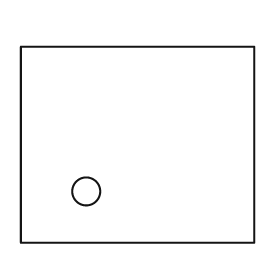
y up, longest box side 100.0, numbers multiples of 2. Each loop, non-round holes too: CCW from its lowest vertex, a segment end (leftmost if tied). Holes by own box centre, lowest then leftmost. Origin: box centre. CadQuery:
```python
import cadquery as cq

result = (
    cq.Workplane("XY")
    .moveTo(-50.0, -42.0)
    .lineTo(50.0, -42.0)
    .lineTo(50.0, 42.0)
    .lineTo(-50.0, 42.0)
    .close()
    .moveTo(-22.0, -20.0)
    .circle(6.0)
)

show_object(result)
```